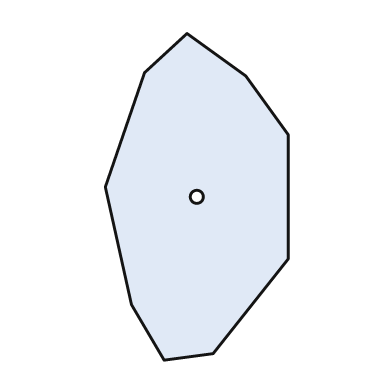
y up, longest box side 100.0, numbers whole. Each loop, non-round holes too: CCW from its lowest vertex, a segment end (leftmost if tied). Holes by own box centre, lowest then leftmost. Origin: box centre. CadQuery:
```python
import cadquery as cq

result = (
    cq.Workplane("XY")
    .moveTo(-10.0, -50.0)
    .lineTo(5.0, -48.0)
    .lineTo(28.0, -19.0)
    .lineTo(28.0, 19.0)
    .lineTo(15.0, 37.0)
    .lineTo(-3.0, 50.0)
    .lineTo(-16.0, 38.0)
    .lineTo(-28.0, 3.0)
    .lineTo(-20.0, -33.0)
    .close()
    .moveTo(0.0, 0.0)
    .circle(2.0)
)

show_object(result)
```